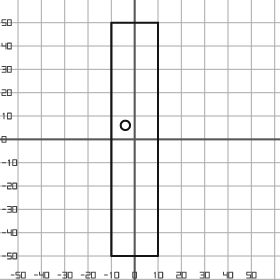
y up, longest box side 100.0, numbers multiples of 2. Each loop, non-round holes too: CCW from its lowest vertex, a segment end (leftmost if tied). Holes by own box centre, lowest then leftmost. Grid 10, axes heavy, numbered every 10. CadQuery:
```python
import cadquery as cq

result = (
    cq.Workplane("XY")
    .moveTo(-10.0, -50.0)
    .lineTo(10.0, -50.0)
    .lineTo(10.0, 50.0)
    .lineTo(-10.0, 50.0)
    .close()
    .moveTo(-4.0, 6.0)
    .circle(2.0)
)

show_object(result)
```